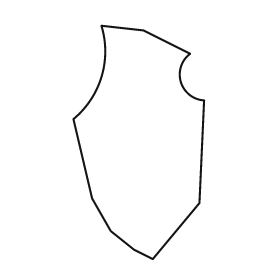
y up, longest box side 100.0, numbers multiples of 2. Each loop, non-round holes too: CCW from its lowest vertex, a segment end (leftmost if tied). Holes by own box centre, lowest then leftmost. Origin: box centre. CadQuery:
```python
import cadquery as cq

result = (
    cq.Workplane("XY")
    .moveTo(6.0, -50.0)
    .lineTo(26.0, -26.0)
    .lineTo(28.0, 18.0)
    .threePointArc((18.0, 26.0), (22.0, 38.0))
    .lineTo(2.0, 48.0)
    .lineTo(-16.0, 50.0)
    .threePointArc((-16.0, 28.0), (-28.0, 10.0))
    .lineTo(-20.0, -24.0)
    .lineTo(-12.0, -38.0)
    .lineTo(-2.0, -46.0)
    .close()
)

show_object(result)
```